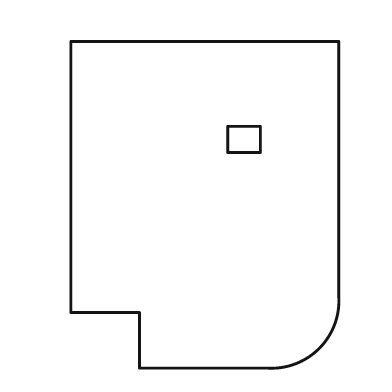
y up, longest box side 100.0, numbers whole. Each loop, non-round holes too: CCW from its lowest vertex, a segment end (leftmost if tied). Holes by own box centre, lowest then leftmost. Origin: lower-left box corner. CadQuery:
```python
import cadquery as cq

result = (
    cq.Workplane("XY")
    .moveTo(21.0, 0.0)
    .lineTo(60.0, 0.0)
    .threePointArc((76.0, 6.0), (82.0, 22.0))
    .lineTo(82.0, 100.0)
    .lineTo(0.0, 100.0)
    .lineTo(0.0, 17.0)
    .lineTo(21.0, 17.0)
    .close()
    .moveTo(48.0, 66.0)
    .lineTo(58.0, 66.0)
    .lineTo(58.0, 74.0)
    .lineTo(48.0, 74.0)
    .close()
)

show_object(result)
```